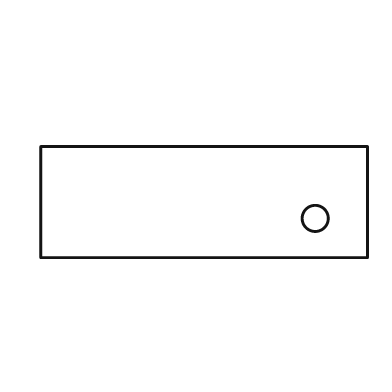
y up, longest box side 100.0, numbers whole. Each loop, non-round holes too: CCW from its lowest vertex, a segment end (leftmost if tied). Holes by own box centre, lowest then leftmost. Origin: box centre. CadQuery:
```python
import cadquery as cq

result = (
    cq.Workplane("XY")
    .moveTo(-50.0, -17.0)
    .lineTo(50.0, -17.0)
    .lineTo(50.0, 17.0)
    .lineTo(-50.0, 17.0)
    .close()
    .moveTo(34.0, -5.0)
    .circle(4.0)
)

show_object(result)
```